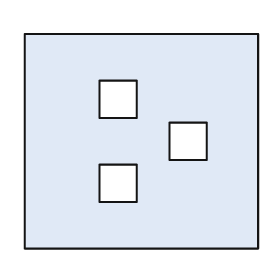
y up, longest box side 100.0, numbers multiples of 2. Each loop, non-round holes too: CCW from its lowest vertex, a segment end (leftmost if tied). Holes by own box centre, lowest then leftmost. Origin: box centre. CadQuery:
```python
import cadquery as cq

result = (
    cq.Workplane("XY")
    .moveTo(-50.0, -46.0)
    .lineTo(50.0, -46.0)
    .lineTo(50.0, 46.0)
    .lineTo(-50.0, 46.0)
    .close()
    .moveTo(-18.0, -26.0)
    .lineTo(-2.0, -26.0)
    .lineTo(-2.0, -10.0)
    .lineTo(-18.0, -10.0)
    .close()
    .moveTo(12.0, -8.0)
    .lineTo(28.0, -8.0)
    .lineTo(28.0, 8.0)
    .lineTo(12.0, 8.0)
    .close()
    .moveTo(-18.0, 10.0)
    .lineTo(-2.0, 10.0)
    .lineTo(-2.0, 26.0)
    .lineTo(-18.0, 26.0)
    .close()
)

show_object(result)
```